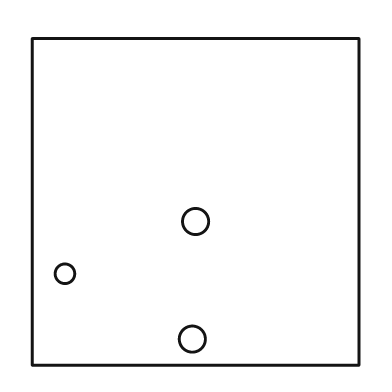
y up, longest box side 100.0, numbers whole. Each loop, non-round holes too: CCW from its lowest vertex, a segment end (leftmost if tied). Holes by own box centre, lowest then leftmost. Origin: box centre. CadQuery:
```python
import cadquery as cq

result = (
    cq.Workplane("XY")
    .moveTo(-50.0, -50.0)
    .lineTo(50.0, -50.0)
    .lineTo(50.0, 50.0)
    .lineTo(-50.0, 50.0)
    .close()
    .moveTo(-1.0, -42.0)
    .circle(4.0)
    .moveTo(-40.0, -22.0)
    .circle(3.0)
    .moveTo(0.0, -6.0)
    .circle(4.0)
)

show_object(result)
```